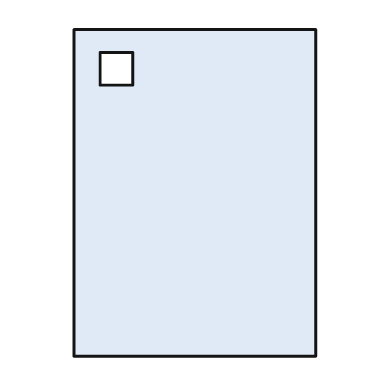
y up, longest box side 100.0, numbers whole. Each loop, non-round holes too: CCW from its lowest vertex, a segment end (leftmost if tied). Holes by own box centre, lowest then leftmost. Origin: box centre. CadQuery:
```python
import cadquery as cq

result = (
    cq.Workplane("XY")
    .moveTo(-37.0, -50.0)
    .lineTo(37.0, -50.0)
    .lineTo(37.0, 50.0)
    .lineTo(-37.0, 50.0)
    .close()
    .moveTo(-29.0, 33.0)
    .lineTo(-19.0, 33.0)
    .lineTo(-19.0, 43.0)
    .lineTo(-29.0, 43.0)
    .close()
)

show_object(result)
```